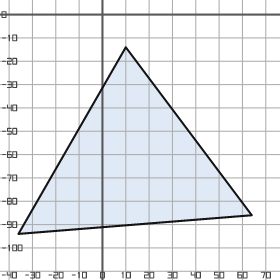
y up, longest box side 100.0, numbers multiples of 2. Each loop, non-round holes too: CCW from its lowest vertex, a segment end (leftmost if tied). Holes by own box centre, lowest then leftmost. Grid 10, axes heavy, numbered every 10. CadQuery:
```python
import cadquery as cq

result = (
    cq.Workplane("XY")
    .moveTo(-36.0, -94.0)
    .lineTo(64.0, -86.0)
    .lineTo(10.0, -14.0)
    .close()
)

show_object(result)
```